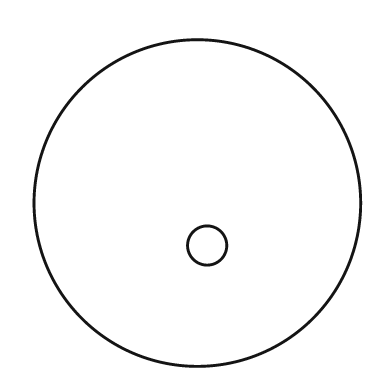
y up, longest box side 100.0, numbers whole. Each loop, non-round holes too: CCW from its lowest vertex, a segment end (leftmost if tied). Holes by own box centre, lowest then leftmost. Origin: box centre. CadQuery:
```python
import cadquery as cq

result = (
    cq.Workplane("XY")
    .moveTo(0.0, 0.0)
    .circle(50.0)
    .moveTo(3.0, -13.0)
    .circle(6.0)
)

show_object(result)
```